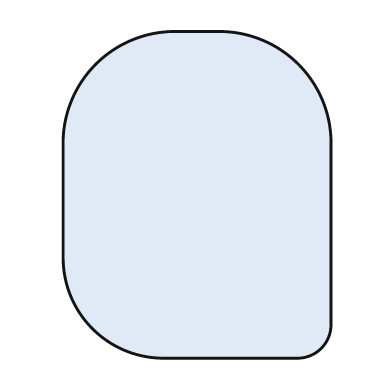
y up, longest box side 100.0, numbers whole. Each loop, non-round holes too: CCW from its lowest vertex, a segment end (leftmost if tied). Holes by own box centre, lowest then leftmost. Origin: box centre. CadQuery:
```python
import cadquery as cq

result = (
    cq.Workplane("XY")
    .moveTo(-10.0, -50.0)
    .lineTo(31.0, -50.0)
    .threePointArc((38.0, -47.0), (41.0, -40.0))
    .lineTo(41.0, 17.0)
    .threePointArc((31.0, 40.0), (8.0, 50.0))
    .lineTo(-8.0, 50.0)
    .threePointArc((-31.0, 40.0), (-41.0, 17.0))
    .lineTo(-41.0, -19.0)
    .threePointArc((-32.0, -41.0), (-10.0, -50.0))
    .close()
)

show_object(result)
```